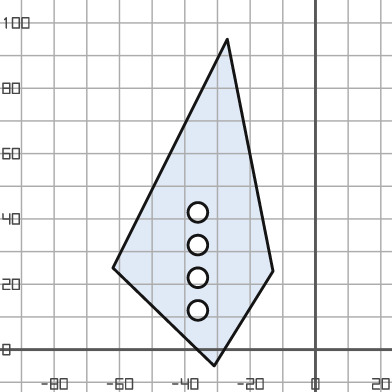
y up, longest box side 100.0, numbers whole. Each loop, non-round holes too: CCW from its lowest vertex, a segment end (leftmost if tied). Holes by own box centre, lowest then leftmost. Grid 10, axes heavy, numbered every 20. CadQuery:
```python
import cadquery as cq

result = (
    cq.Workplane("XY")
    .moveTo(-31.0, -5.0)
    .lineTo(-13.0, 24.0)
    .lineTo(-27.0, 95.0)
    .lineTo(-62.0, 25.0)
    .close()
    .moveTo(-36.0, 12.0)
    .circle(3.0)
    .moveTo(-36.0, 22.0)
    .circle(3.0)
    .moveTo(-36.0, 32.0)
    .circle(3.0)
    .moveTo(-36.0, 42.0)
    .circle(3.0)
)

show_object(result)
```